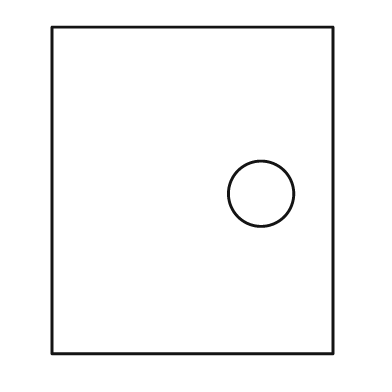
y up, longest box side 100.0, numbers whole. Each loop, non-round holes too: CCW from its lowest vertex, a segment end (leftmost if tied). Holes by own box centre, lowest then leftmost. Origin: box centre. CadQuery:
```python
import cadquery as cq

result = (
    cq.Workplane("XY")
    .moveTo(-43.0, -50.0)
    .lineTo(43.0, -50.0)
    .lineTo(43.0, 50.0)
    .lineTo(-43.0, 50.0)
    .close()
    .moveTo(21.0, -1.0)
    .circle(10.0)
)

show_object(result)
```